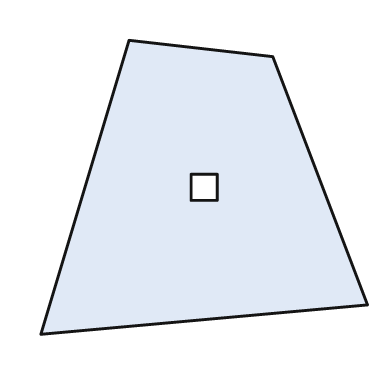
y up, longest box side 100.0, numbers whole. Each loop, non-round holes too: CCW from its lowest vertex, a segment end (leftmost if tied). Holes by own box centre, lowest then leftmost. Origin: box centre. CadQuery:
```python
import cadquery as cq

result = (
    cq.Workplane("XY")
    .moveTo(-50.0, -45.0)
    .lineTo(50.0, -36.0)
    .lineTo(21.0, 40.0)
    .lineTo(-23.0, 45.0)
    .close()
    .moveTo(-4.0, -4.0)
    .lineTo(4.0, -4.0)
    .lineTo(4.0, 4.0)
    .lineTo(-4.0, 4.0)
    .close()
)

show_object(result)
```